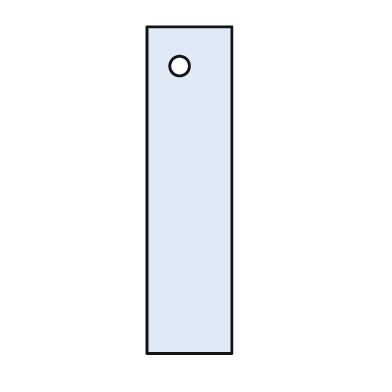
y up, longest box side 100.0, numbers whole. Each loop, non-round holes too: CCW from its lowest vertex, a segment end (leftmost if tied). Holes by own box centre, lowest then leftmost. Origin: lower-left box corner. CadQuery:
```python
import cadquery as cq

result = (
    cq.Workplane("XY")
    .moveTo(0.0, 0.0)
    .lineTo(26.0, 0.0)
    .lineTo(26.0, 100.0)
    .lineTo(0.0, 100.0)
    .close()
    .moveTo(10.0, 88.0)
    .circle(3.0)
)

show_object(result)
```